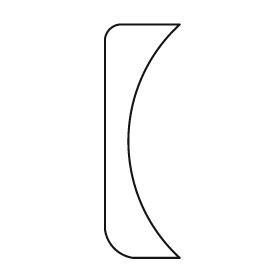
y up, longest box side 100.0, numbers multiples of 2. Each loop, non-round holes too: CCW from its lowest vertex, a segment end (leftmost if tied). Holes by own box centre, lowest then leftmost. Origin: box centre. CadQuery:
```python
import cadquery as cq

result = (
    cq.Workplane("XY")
    .moveTo(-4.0, -50.0)
    .lineTo(16.0, -50.0)
    .threePointArc((-6.0, 0.0), (16.0, 50.0))
    .lineTo(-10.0, 50.0)
    .threePointArc((-14.0, 48.0), (-16.0, 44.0))
    .lineTo(-16.0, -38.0)
    .threePointArc((-12.0, -46.0), (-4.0, -50.0))
    .close()
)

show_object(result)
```